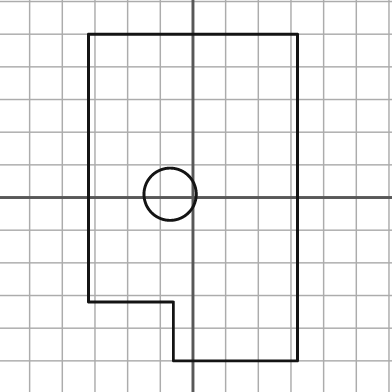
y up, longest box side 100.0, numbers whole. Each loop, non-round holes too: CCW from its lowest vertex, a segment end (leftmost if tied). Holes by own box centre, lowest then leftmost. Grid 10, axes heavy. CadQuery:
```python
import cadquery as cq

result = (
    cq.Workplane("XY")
    .moveTo(-6.0, -50.0)
    .lineTo(32.0, -50.0)
    .lineTo(32.0, 50.0)
    .lineTo(-32.0, 50.0)
    .lineTo(-32.0, -32.0)
    .lineTo(-6.0, -32.0)
    .close()
    .moveTo(-7.0, 1.0)
    .circle(8.0)
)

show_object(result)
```